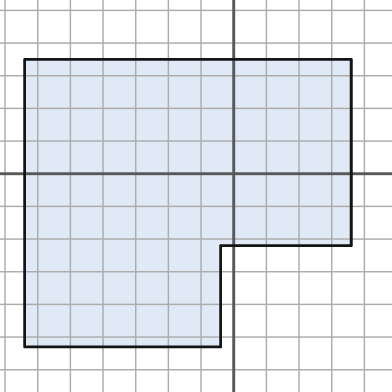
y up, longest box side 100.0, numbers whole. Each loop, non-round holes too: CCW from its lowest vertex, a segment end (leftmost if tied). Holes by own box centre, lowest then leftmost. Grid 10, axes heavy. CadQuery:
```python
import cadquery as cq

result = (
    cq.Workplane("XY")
    .moveTo(-64.0, -53.0)
    .lineTo(-4.0, -53.0)
    .lineTo(-4.0, -22.0)
    .lineTo(36.0, -22.0)
    .lineTo(36.0, 35.0)
    .lineTo(-64.0, 35.0)
    .close()
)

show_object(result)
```